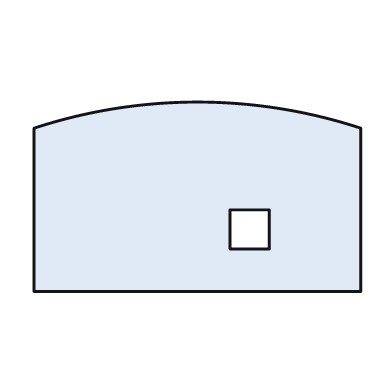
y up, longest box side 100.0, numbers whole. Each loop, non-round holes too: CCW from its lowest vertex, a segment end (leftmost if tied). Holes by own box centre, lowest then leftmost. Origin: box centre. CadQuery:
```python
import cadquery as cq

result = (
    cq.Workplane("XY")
    .moveTo(-50.0, -29.0)
    .lineTo(50.0, -29.0)
    .lineTo(50.0, 21.0)
    .threePointArc((0.0, 29.0), (-50.0, 21.0))
    .close()
    .moveTo(10.0, -16.0)
    .lineTo(22.0, -16.0)
    .lineTo(22.0, -4.0)
    .lineTo(10.0, -4.0)
    .close()
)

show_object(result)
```